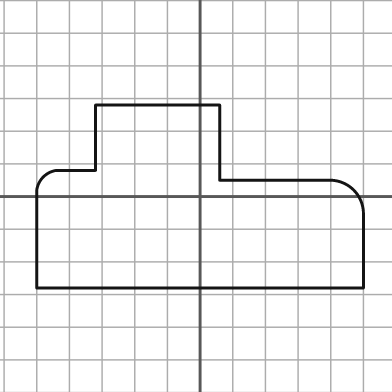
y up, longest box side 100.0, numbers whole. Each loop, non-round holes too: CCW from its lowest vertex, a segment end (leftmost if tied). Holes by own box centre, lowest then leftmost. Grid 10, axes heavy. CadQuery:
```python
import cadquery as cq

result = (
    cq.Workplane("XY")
    .moveTo(-50.0, -28.0)
    .lineTo(50.0, -28.0)
    .lineTo(50.0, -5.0)
    .threePointArc((47.0, 2.0), (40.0, 5.0))
    .lineTo(6.0, 5.0)
    .lineTo(6.0, 28.0)
    .lineTo(-32.0, 28.0)
    .lineTo(-32.0, 8.0)
    .lineTo(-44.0, 8.0)
    .threePointArc((-48.0, 6.0), (-50.0, 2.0))
    .close()
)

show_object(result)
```